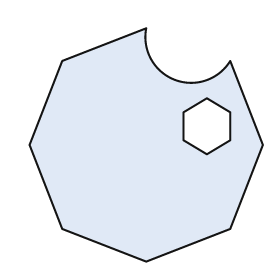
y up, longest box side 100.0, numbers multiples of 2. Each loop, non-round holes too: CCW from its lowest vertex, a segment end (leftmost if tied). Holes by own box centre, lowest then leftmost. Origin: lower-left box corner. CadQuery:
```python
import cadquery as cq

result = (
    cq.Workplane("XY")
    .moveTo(50.0, 0.0)
    .lineTo(86.0, 14.0)
    .lineTo(100.0, 50.0)
    .lineTo(86.0, 86.0)
    .threePointArc((62.0, 78.0), (50.0, 100.0))
    .lineTo(14.0, 86.0)
    .lineTo(0.0, 50.0)
    .lineTo(14.0, 14.0)
    .close()
    .moveTo(76.0, 46.0)
    .lineTo(86.0, 52.0)
    .lineTo(86.0, 64.0)
    .lineTo(76.0, 70.0)
    .lineTo(66.0, 64.0)
    .lineTo(66.0, 52.0)
    .close()
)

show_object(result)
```